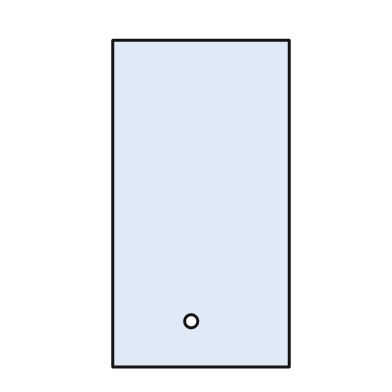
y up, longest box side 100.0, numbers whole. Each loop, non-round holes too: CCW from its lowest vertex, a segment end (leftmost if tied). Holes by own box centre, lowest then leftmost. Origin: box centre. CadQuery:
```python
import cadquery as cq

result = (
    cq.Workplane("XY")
    .moveTo(-27.0, -50.0)
    .lineTo(27.0, -50.0)
    .lineTo(27.0, 50.0)
    .lineTo(-27.0, 50.0)
    .close()
    .moveTo(-3.0, -36.0)
    .circle(2.0)
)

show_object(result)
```